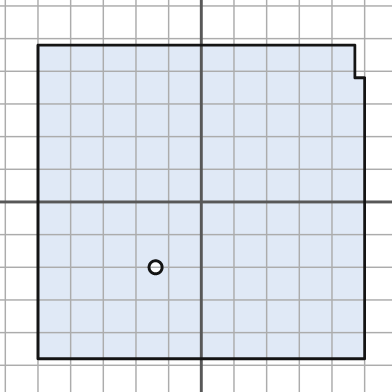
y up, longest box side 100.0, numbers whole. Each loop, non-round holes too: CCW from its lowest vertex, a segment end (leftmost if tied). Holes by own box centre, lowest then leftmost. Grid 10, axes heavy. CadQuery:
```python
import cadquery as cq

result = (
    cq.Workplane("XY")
    .moveTo(-50.0, -48.0)
    .lineTo(50.0, -48.0)
    .lineTo(50.0, 38.0)
    .lineTo(47.0, 38.0)
    .lineTo(47.0, 48.0)
    .lineTo(-50.0, 48.0)
    .close()
    .moveTo(-14.0, -20.0)
    .circle(2.0)
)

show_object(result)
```